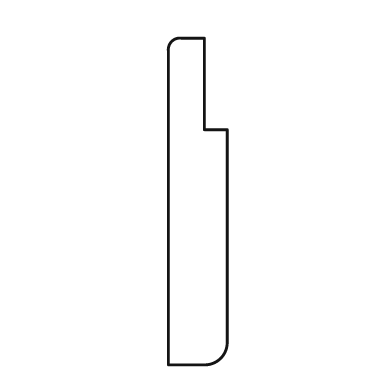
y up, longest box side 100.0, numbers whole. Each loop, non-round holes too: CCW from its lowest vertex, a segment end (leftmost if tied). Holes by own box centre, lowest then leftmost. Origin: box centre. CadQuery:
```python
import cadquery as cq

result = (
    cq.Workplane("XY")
    .moveTo(-9.0, -50.0)
    .lineTo(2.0, -50.0)
    .threePointArc((7.0, -48.0), (9.0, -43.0))
    .lineTo(9.0, 22.0)
    .lineTo(2.0, 22.0)
    .lineTo(2.0, 50.0)
    .lineTo(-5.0, 50.0)
    .threePointArc((-8.0, 49.0), (-9.0, 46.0))
    .close()
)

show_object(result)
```